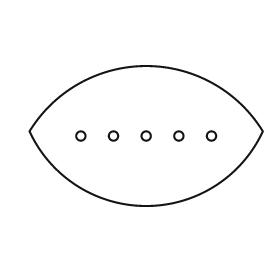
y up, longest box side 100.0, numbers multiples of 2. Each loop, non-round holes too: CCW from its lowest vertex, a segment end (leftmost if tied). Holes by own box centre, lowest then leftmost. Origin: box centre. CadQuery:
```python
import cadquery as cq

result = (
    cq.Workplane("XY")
    .moveTo(-50.0, 2.0)
    .threePointArc((0.0, -30.0), (50.0, 2.0))
    .threePointArc((0.0, 30.0), (-50.0, 2.0))
    .close()
    .moveTo(-28.0, 0.0)
    .circle(2.0)
    .moveTo(-14.0, 0.0)
    .circle(2.0)
    .moveTo(0.0, 0.0)
    .circle(2.0)
    .moveTo(14.0, 0.0)
    .circle(2.0)
    .moveTo(28.0, 0.0)
    .circle(2.0)
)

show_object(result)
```